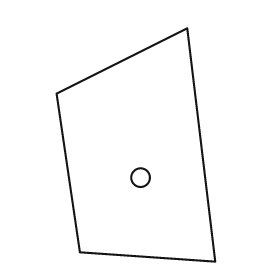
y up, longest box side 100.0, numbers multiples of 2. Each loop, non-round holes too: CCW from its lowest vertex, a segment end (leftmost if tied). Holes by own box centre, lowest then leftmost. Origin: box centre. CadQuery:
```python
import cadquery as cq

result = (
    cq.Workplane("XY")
    .moveTo(34.0, -50.0)
    .lineTo(22.0, 50.0)
    .lineTo(-34.0, 22.0)
    .lineTo(-24.0, -46.0)
    .close()
    .moveTo(2.0, -14.0)
    .circle(4.0)
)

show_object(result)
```